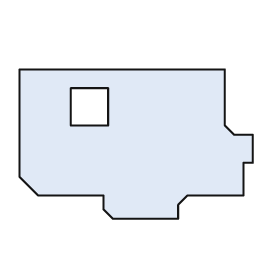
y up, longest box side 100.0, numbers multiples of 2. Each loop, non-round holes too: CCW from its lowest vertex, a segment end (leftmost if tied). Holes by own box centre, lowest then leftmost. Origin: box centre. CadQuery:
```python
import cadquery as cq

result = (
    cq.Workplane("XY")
    .moveTo(-10.0, -32.0)
    .lineTo(18.0, -32.0)
    .lineTo(18.0, -26.0)
    .lineTo(22.0, -22.0)
    .lineTo(46.0, -22.0)
    .lineTo(46.0, -8.0)
    .lineTo(50.0, -8.0)
    .lineTo(50.0, 4.0)
    .lineTo(42.0, 4.0)
    .lineTo(38.0, 8.0)
    .lineTo(38.0, 32.0)
    .lineTo(-50.0, 32.0)
    .lineTo(-50.0, -14.0)
    .lineTo(-42.0, -22.0)
    .lineTo(-14.0, -22.0)
    .lineTo(-14.0, -28.0)
    .close()
    .moveTo(-28.0, 8.0)
    .lineTo(-12.0, 8.0)
    .lineTo(-12.0, 24.0)
    .lineTo(-28.0, 24.0)
    .close()
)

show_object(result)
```